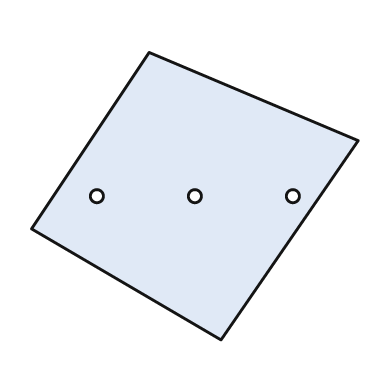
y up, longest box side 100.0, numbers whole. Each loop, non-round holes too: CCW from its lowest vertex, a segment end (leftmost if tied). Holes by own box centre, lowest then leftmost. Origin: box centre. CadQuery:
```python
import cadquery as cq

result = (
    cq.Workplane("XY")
    .moveTo(8.0, -44.0)
    .lineTo(50.0, 17.0)
    .lineTo(-14.0, 44.0)
    .lineTo(-50.0, -10.0)
    .close()
    .moveTo(-30.0, 0.0)
    .circle(2.0)
    .moveTo(0.0, 0.0)
    .circle(2.0)
    .moveTo(30.0, 0.0)
    .circle(2.0)
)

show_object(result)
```